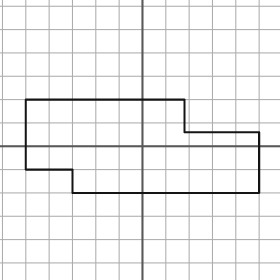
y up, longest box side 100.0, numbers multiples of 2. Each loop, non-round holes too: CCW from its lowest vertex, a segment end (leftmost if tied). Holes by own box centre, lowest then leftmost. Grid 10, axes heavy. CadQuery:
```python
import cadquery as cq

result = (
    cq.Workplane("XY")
    .moveTo(-30.0, -20.0)
    .lineTo(50.0, -20.0)
    .lineTo(50.0, 6.0)
    .lineTo(18.0, 6.0)
    .lineTo(18.0, 20.0)
    .lineTo(-50.0, 20.0)
    .lineTo(-50.0, -10.0)
    .lineTo(-30.0, -10.0)
    .close()
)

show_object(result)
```